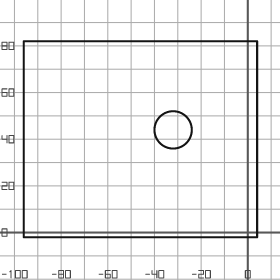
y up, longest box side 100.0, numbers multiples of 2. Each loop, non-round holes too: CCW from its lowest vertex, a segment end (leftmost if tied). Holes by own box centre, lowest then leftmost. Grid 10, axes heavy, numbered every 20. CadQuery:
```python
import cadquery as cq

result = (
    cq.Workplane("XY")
    .moveTo(-96.0, -2.0)
    .lineTo(4.0, -2.0)
    .lineTo(4.0, 82.0)
    .lineTo(-96.0, 82.0)
    .close()
    .moveTo(-32.0, 44.0)
    .circle(8.0)
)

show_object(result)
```